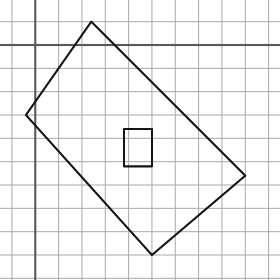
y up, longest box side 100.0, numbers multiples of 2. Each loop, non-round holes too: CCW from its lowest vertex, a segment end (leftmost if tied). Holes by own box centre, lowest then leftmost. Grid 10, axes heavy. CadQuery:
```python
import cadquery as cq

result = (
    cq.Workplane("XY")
    .moveTo(50.0, -90.0)
    .lineTo(90.0, -56.0)
    .lineTo(24.0, 10.0)
    .lineTo(-4.0, -30.0)
    .close()
    .moveTo(38.0, -52.0)
    .lineTo(50.0, -52.0)
    .lineTo(50.0, -36.0)
    .lineTo(38.0, -36.0)
    .close()
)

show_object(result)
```